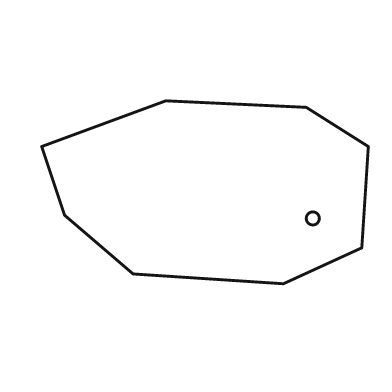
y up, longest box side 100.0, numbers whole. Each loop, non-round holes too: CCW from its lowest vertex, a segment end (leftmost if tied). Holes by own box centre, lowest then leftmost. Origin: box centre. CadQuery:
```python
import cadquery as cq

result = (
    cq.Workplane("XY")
    .moveTo(24.0, -28.0)
    .lineTo(48.0, -17.0)
    .lineTo(50.0, 14.0)
    .lineTo(31.0, 26.0)
    .lineTo(-12.0, 28.0)
    .lineTo(-50.0, 14.0)
    .lineTo(-43.0, -7.0)
    .lineTo(-22.0, -25.0)
    .close()
    .moveTo(33.0, -8.0)
    .circle(2.0)
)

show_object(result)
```